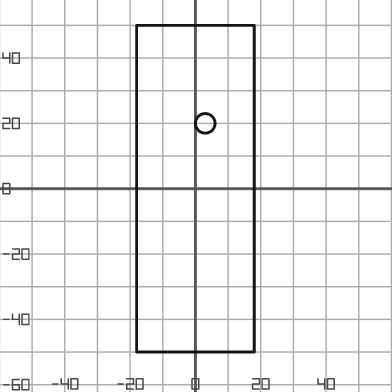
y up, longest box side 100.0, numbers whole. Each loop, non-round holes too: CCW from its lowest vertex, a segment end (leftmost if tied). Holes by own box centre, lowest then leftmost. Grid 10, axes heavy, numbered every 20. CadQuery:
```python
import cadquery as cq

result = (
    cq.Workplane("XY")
    .moveTo(-18.0, -50.0)
    .lineTo(18.0, -50.0)
    .lineTo(18.0, 50.0)
    .lineTo(-18.0, 50.0)
    .close()
    .moveTo(3.0, 20.0)
    .circle(3.0)
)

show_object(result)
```